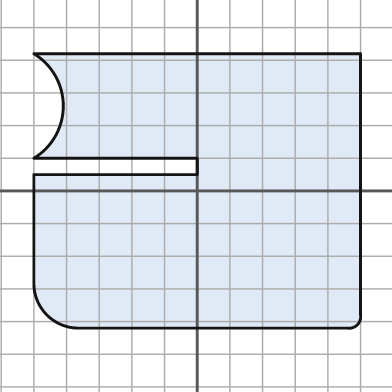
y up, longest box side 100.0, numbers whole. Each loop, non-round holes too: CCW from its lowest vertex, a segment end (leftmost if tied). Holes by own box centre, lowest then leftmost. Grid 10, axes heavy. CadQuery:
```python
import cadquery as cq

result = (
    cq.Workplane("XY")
    .moveTo(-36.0, -42.0)
    .lineTo(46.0, -42.0)
    .threePointArc((49.0, -41.0), (50.0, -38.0))
    .lineTo(50.0, 42.0)
    .lineTo(-50.0, 42.0)
    .threePointArc((-41.0, 26.0), (-50.0, 10.0))
    .lineTo(0.0, 10.0)
    .lineTo(0.0, 5.0)
    .lineTo(-50.0, 5.0)
    .lineTo(-50.0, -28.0)
    .threePointArc((-46.0, -38.0), (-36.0, -42.0))
    .close()
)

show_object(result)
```